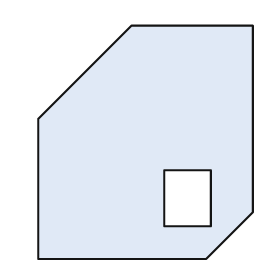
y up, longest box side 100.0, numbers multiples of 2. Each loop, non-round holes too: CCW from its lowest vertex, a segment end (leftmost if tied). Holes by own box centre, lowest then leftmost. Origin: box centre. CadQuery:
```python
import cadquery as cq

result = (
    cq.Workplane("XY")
    .moveTo(-46.0, -50.0)
    .lineTo(26.0, -50.0)
    .lineTo(46.0, -30.0)
    .lineTo(46.0, 50.0)
    .lineTo(-6.0, 50.0)
    .lineTo(-46.0, 10.0)
    .close()
    .moveTo(8.0, -36.0)
    .lineTo(28.0, -36.0)
    .lineTo(28.0, -12.0)
    .lineTo(8.0, -12.0)
    .close()
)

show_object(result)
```